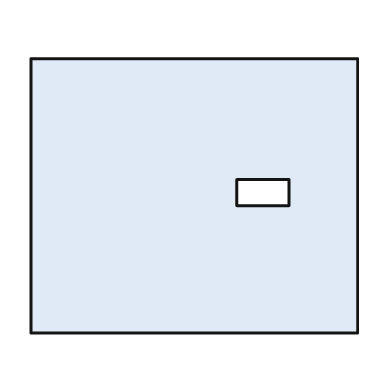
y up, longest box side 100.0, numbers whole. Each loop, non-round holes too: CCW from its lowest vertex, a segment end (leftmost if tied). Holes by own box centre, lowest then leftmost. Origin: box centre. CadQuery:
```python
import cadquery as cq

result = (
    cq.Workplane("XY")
    .moveTo(-50.0, -42.0)
    .lineTo(50.0, -42.0)
    .lineTo(50.0, 42.0)
    .lineTo(-50.0, 42.0)
    .close()
    .moveTo(13.0, -3.0)
    .lineTo(29.0, -3.0)
    .lineTo(29.0, 5.0)
    .lineTo(13.0, 5.0)
    .close()
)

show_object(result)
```